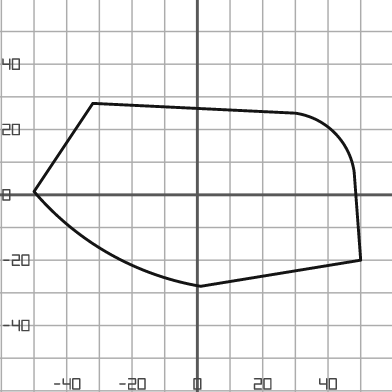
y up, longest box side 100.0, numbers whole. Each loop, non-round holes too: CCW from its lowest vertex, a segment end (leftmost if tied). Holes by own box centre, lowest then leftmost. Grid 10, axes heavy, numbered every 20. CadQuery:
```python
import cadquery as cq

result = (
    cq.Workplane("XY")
    .moveTo(1.0, -28.0)
    .lineTo(50.0, -20.0)
    .lineTo(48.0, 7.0)
    .threePointArc((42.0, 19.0), (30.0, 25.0))
    .lineTo(-32.0, 28.0)
    .lineTo(-50.0, 1.0)
    .threePointArc((-27.0, -18.0), (1.0, -28.0))
    .close()
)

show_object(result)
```